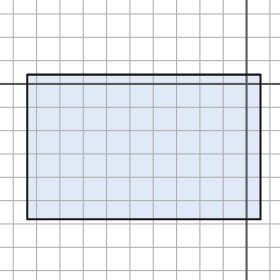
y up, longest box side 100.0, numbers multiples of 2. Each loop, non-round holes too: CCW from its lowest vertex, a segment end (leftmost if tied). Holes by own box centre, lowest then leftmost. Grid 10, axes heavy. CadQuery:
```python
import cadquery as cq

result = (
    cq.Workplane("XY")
    .moveTo(-94.0, -58.0)
    .lineTo(6.0, -58.0)
    .lineTo(6.0, 4.0)
    .lineTo(-94.0, 4.0)
    .close()
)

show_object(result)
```